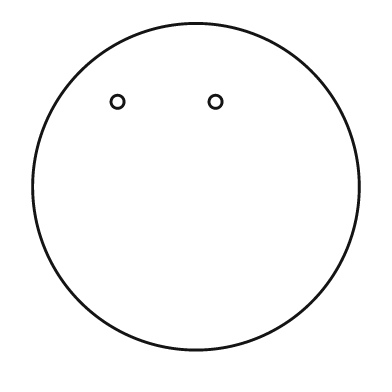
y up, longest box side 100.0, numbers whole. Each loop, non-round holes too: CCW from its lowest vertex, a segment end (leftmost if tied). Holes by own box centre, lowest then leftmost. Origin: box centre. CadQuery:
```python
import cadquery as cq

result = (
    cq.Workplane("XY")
    .moveTo(0.0, 0.0)
    .circle(50.0)
    .moveTo(-24.0, 26.0)
    .circle(2.0)
    .moveTo(6.0, 26.0)
    .circle(2.0)
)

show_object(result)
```